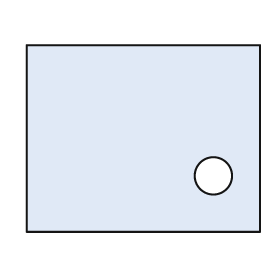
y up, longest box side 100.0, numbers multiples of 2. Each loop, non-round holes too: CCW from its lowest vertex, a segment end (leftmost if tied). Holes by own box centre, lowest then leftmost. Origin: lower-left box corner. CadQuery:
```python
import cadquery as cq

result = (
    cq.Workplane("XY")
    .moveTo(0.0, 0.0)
    .lineTo(100.0, 0.0)
    .lineTo(100.0, 80.0)
    .lineTo(0.0, 80.0)
    .close()
    .moveTo(80.0, 24.0)
    .circle(8.0)
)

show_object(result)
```